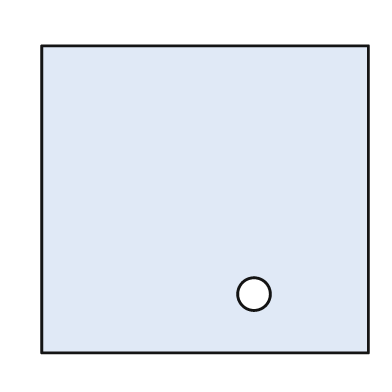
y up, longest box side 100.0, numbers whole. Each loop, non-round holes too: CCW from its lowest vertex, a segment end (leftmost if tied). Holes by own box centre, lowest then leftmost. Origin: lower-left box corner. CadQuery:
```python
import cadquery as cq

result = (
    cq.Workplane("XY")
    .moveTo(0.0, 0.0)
    .lineTo(100.0, 0.0)
    .lineTo(100.0, 94.0)
    .lineTo(0.0, 94.0)
    .close()
    .moveTo(65.0, 18.0)
    .circle(5.0)
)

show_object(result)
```